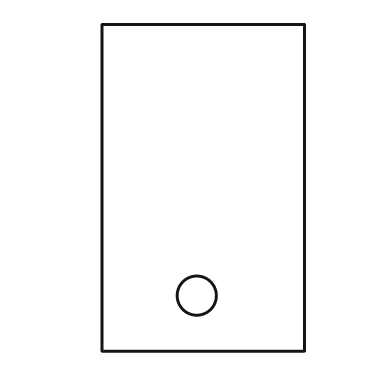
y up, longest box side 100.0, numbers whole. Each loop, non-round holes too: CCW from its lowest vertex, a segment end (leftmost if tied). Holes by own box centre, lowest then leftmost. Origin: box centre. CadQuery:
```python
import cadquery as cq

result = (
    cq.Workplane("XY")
    .moveTo(-31.0, -50.0)
    .lineTo(31.0, -50.0)
    .lineTo(31.0, 50.0)
    .lineTo(-31.0, 50.0)
    .close()
    .moveTo(-2.0, -33.0)
    .circle(6.0)
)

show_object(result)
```